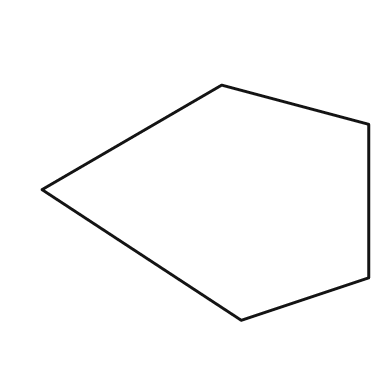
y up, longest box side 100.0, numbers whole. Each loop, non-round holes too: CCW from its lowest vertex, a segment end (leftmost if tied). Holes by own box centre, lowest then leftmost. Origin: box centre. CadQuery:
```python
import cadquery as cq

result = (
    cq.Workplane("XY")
    .moveTo(11.0, -36.0)
    .lineTo(50.0, -23.0)
    .lineTo(50.0, 24.0)
    .lineTo(5.0, 36.0)
    .lineTo(-50.0, 4.0)
    .close()
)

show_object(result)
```